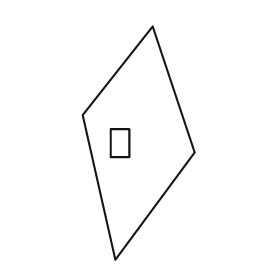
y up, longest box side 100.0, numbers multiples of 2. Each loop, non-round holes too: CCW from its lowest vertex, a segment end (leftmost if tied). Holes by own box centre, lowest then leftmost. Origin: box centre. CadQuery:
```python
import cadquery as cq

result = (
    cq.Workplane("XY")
    .moveTo(-10.0, -50.0)
    .lineTo(24.0, -4.0)
    .lineTo(6.0, 50.0)
    .lineTo(-24.0, 12.0)
    .close()
    .moveTo(-12.0, -6.0)
    .lineTo(-4.0, -6.0)
    .lineTo(-4.0, 6.0)
    .lineTo(-12.0, 6.0)
    .close()
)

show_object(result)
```